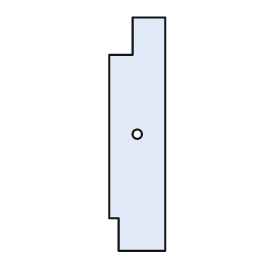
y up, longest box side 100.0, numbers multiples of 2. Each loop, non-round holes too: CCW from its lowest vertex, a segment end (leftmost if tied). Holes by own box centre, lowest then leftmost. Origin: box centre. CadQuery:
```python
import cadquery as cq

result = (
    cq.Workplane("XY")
    .moveTo(-8.0, -50.0)
    .lineTo(12.0, -50.0)
    .lineTo(12.0, 50.0)
    .lineTo(-2.0, 50.0)
    .lineTo(-2.0, 34.0)
    .lineTo(-12.0, 34.0)
    .lineTo(-12.0, -36.0)
    .lineTo(-8.0, -36.0)
    .close()
    .moveTo(0.0, 0.0)
    .circle(2.0)
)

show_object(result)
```